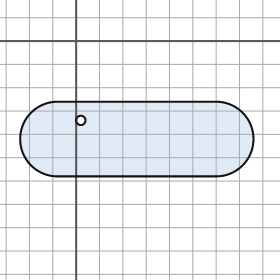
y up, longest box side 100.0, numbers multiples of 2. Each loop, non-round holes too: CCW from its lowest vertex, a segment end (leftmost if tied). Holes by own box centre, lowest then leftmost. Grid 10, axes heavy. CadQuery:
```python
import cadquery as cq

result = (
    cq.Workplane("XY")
    .moveTo(-8.0, -58.0)
    .lineTo(60.0, -58.0)
    .threePointArc((76.0, -42.0), (60.0, -26.0))
    .lineTo(-8.0, -26.0)
    .threePointArc((-24.0, -42.0), (-8.0, -58.0))
    .close()
    .moveTo(2.0, -34.0)
    .circle(2.0)
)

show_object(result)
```